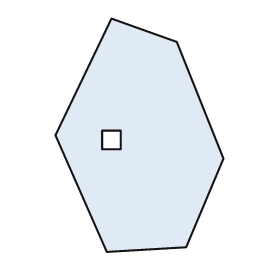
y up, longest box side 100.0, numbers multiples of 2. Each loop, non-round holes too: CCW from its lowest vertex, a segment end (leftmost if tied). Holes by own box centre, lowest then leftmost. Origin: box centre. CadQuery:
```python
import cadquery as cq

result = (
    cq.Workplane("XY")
    .moveTo(-14.0, -50.0)
    .lineTo(20.0, -48.0)
    .lineTo(36.0, -10.0)
    .lineTo(16.0, 40.0)
    .lineTo(-12.0, 50.0)
    .lineTo(-36.0, 0.0)
    .close()
    .moveTo(-16.0, -6.0)
    .lineTo(-8.0, -6.0)
    .lineTo(-8.0, 2.0)
    .lineTo(-16.0, 2.0)
    .close()
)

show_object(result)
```